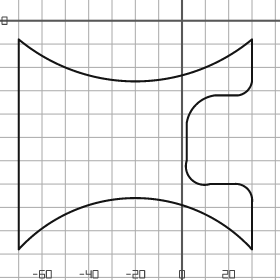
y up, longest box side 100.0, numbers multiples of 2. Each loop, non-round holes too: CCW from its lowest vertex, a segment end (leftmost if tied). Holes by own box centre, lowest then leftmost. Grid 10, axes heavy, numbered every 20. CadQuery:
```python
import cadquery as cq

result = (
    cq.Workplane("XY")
    .moveTo(-70.0, -98.0)
    .threePointArc((-20.0, -76.0), (30.0, -98.0))
    .lineTo(30.0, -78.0)
    .threePointArc((28.0, -72.0), (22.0, -70.0))
    .lineTo(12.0, -70.0)
    .threePointArc((4.0, -68.0), (2.0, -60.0))
    .lineTo(2.0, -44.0)
    .threePointArc((6.0, -36.0), (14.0, -32.0))
    .lineTo(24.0, -32.0)
    .threePointArc((28.0, -30.0), (30.0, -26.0))
    .lineTo(30.0, -8.0)
    .threePointArc((-20.0, -26.0), (-70.0, -8.0))
    .close()
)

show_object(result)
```